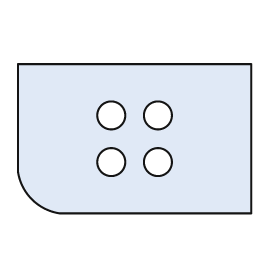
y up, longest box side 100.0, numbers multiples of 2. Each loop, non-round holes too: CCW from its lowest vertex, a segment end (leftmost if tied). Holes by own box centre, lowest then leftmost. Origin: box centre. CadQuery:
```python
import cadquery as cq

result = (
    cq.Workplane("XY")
    .moveTo(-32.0, -32.0)
    .lineTo(50.0, -32.0)
    .lineTo(50.0, 32.0)
    .lineTo(-50.0, 32.0)
    .lineTo(-50.0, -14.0)
    .threePointArc((-44.0, -26.0), (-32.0, -32.0))
    .close()
    .moveTo(-10.0, -10.0)
    .circle(6.0)
    .moveTo(10.0, -10.0)
    .circle(6.0)
    .moveTo(-10.0, 10.0)
    .circle(6.0)
    .moveTo(10.0, 10.0)
    .circle(6.0)
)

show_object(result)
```